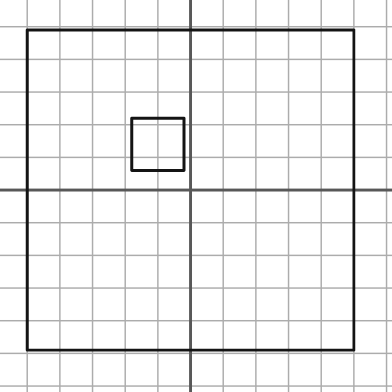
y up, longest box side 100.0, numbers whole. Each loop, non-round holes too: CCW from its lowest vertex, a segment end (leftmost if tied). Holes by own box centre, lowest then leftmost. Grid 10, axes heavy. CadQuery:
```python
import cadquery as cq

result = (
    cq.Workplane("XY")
    .moveTo(-50.0, -49.0)
    .lineTo(50.0, -49.0)
    .lineTo(50.0, 49.0)
    .lineTo(-50.0, 49.0)
    .close()
    .moveTo(-18.0, 6.0)
    .lineTo(-2.0, 6.0)
    .lineTo(-2.0, 22.0)
    .lineTo(-18.0, 22.0)
    .close()
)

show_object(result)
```